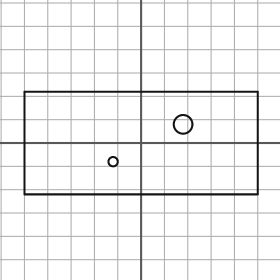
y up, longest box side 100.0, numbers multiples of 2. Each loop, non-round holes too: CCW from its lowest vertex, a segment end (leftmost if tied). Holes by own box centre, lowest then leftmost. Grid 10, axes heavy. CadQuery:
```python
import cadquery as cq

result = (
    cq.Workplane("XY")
    .moveTo(-50.0, -22.0)
    .lineTo(50.0, -22.0)
    .lineTo(50.0, 22.0)
    .lineTo(-50.0, 22.0)
    .close()
    .moveTo(-12.0, -8.0)
    .circle(2.0)
    .moveTo(18.0, 8.0)
    .circle(4.0)
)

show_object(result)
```